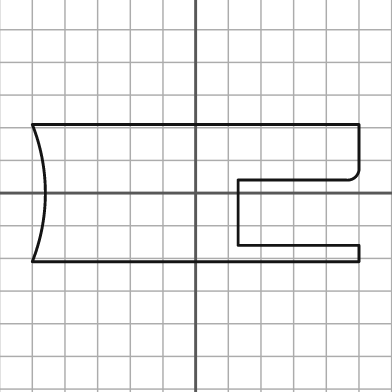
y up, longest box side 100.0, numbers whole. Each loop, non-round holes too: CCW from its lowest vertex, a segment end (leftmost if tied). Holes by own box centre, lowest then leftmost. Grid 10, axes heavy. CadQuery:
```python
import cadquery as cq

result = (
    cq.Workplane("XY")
    .moveTo(-50.0, -21.0)
    .lineTo(50.0, -21.0)
    .lineTo(50.0, -16.0)
    .lineTo(13.0, -16.0)
    .lineTo(13.0, 4.0)
    .lineTo(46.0, 4.0)
    .threePointArc((49.0, 5.0), (50.0, 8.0))
    .lineTo(50.0, 21.0)
    .lineTo(-50.0, 21.0)
    .threePointArc((-46.0, 0.0), (-50.0, -21.0))
    .close()
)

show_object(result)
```